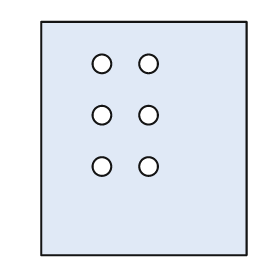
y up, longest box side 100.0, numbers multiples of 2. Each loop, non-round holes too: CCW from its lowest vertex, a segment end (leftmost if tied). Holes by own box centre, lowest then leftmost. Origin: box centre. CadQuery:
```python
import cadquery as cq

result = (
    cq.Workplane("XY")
    .moveTo(-44.0, -50.0)
    .lineTo(44.0, -50.0)
    .lineTo(44.0, 50.0)
    .lineTo(-44.0, 50.0)
    .close()
    .moveTo(-18.0, -12.0)
    .circle(4.0)
    .moveTo(2.0, -12.0)
    .circle(4.0)
    .moveTo(-18.0, 10.0)
    .circle(4.0)
    .moveTo(2.0, 10.0)
    .circle(4.0)
    .moveTo(-18.0, 32.0)
    .circle(4.0)
    .moveTo(2.0, 32.0)
    .circle(4.0)
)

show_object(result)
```